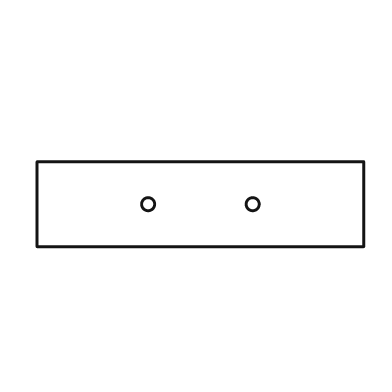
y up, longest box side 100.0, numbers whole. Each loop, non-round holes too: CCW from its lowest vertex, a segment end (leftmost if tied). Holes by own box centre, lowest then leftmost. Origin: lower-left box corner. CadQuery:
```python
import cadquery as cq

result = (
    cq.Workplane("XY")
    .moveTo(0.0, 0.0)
    .lineTo(100.0, 0.0)
    .lineTo(100.0, 26.0)
    .lineTo(0.0, 26.0)
    .close()
    .moveTo(34.0, 13.0)
    .circle(2.0)
    .moveTo(66.0, 13.0)
    .circle(2.0)
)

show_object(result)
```